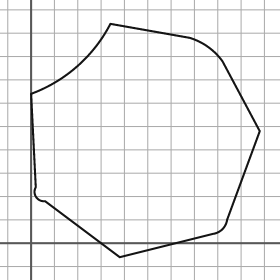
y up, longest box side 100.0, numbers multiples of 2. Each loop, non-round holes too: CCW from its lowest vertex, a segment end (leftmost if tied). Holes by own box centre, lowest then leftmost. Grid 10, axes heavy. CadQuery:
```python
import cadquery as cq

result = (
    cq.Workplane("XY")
    .moveTo(38.0, -6.0)
    .lineTo(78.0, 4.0)
    .threePointArc((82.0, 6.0), (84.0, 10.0))
    .lineTo(98.0, 48.0)
    .lineTo(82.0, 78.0)
    .threePointArc((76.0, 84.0), (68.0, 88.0))
    .lineTo(34.0, 94.0)
    .threePointArc((20.0, 76.0), (0.0, 64.0))
    .lineTo(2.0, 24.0)
    .threePointArc((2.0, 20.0), (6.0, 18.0))
    .close()
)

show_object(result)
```